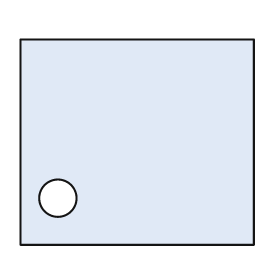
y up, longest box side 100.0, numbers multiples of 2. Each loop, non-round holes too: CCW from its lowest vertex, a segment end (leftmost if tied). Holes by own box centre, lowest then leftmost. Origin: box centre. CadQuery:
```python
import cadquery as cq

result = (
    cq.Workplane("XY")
    .moveTo(-50.0, -44.0)
    .lineTo(50.0, -44.0)
    .lineTo(50.0, 44.0)
    .lineTo(-50.0, 44.0)
    .close()
    .moveTo(-34.0, -24.0)
    .circle(8.0)
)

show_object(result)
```